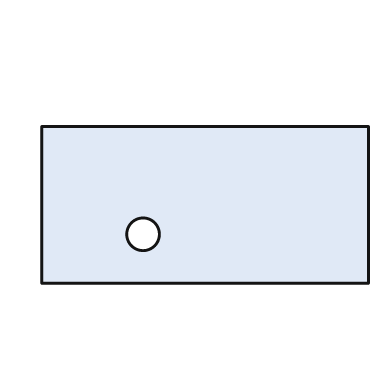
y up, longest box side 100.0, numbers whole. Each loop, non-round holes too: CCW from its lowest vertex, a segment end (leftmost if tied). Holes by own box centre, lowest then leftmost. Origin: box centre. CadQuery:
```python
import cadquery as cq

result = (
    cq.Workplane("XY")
    .moveTo(-50.0, -24.0)
    .lineTo(50.0, -24.0)
    .lineTo(50.0, 24.0)
    .lineTo(-50.0, 24.0)
    .close()
    .moveTo(-19.0, -9.0)
    .circle(5.0)
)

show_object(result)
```